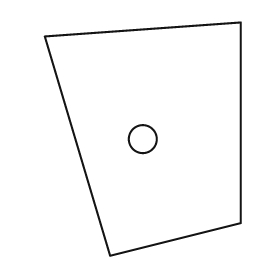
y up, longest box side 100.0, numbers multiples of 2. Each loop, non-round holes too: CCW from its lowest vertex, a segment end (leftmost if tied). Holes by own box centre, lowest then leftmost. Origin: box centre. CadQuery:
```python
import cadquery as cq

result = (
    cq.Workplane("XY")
    .moveTo(-14.0, -50.0)
    .lineTo(42.0, -36.0)
    .lineTo(42.0, 50.0)
    .lineTo(-42.0, 44.0)
    .close()
    .moveTo(0.0, 0.0)
    .circle(6.0)
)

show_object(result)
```